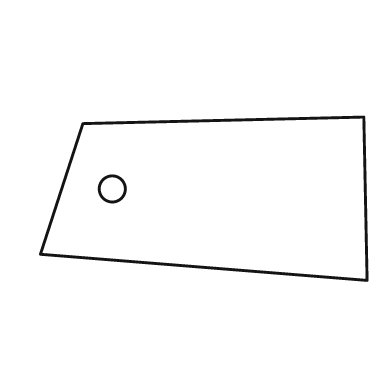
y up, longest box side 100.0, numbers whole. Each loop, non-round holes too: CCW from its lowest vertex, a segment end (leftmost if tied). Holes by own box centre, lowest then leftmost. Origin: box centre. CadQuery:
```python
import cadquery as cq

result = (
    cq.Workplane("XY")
    .moveTo(50.0, -25.0)
    .lineTo(49.0, 25.0)
    .lineTo(-37.0, 23.0)
    .lineTo(-50.0, -17.0)
    .close()
    .moveTo(-28.0, 3.0)
    .circle(4.0)
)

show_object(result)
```